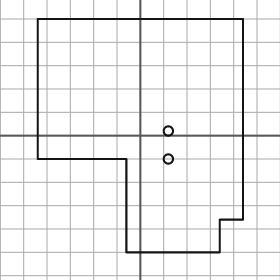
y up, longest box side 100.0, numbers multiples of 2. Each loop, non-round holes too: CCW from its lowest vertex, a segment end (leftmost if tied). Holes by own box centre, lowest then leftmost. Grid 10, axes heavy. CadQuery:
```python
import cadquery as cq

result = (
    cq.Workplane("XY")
    .moveTo(-6.0, -50.0)
    .lineTo(34.0, -50.0)
    .lineTo(34.0, -36.0)
    .lineTo(44.0, -36.0)
    .lineTo(44.0, 50.0)
    .lineTo(-44.0, 50.0)
    .lineTo(-44.0, -10.0)
    .lineTo(-6.0, -10.0)
    .close()
    .moveTo(12.0, -10.0)
    .circle(2.0)
    .moveTo(12.0, 2.0)
    .circle(2.0)
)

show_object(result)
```